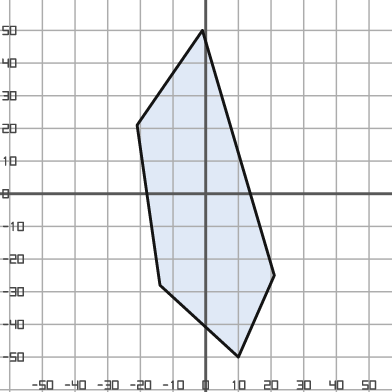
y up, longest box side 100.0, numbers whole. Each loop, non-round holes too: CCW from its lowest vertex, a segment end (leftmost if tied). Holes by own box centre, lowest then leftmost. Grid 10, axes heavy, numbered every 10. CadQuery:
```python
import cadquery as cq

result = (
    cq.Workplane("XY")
    .moveTo(10.0, -50.0)
    .lineTo(21.0, -25.0)
    .lineTo(-1.0, 50.0)
    .lineTo(-21.0, 21.0)
    .lineTo(-14.0, -28.0)
    .close()
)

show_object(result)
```